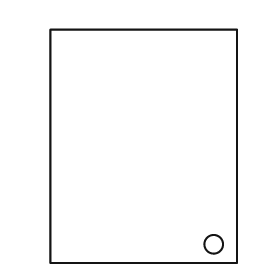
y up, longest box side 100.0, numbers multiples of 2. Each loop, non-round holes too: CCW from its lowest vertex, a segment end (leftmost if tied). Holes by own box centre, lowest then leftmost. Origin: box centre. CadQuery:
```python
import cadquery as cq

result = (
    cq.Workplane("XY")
    .moveTo(-40.0, -50.0)
    .lineTo(40.0, -50.0)
    .lineTo(40.0, 50.0)
    .lineTo(-40.0, 50.0)
    .close()
    .moveTo(30.0, -42.0)
    .circle(4.0)
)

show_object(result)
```